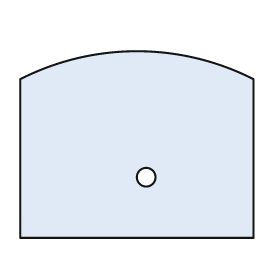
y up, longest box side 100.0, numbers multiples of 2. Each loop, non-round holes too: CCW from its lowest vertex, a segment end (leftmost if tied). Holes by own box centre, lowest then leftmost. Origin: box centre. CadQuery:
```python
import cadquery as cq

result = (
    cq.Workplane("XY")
    .moveTo(-50.0, -40.0)
    .lineTo(50.0, -40.0)
    .lineTo(50.0, 28.0)
    .threePointArc((0.0, 40.0), (-50.0, 28.0))
    .close()
    .moveTo(4.0, -14.0)
    .circle(4.0)
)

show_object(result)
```